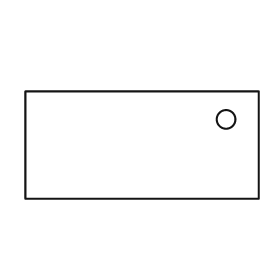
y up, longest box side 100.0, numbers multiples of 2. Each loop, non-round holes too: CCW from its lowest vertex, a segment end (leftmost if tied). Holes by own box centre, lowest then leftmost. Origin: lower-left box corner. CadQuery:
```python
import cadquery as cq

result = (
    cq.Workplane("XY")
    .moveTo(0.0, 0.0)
    .lineTo(100.0, 0.0)
    .lineTo(100.0, 46.0)
    .lineTo(0.0, 46.0)
    .close()
    .moveTo(86.0, 34.0)
    .circle(4.0)
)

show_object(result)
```